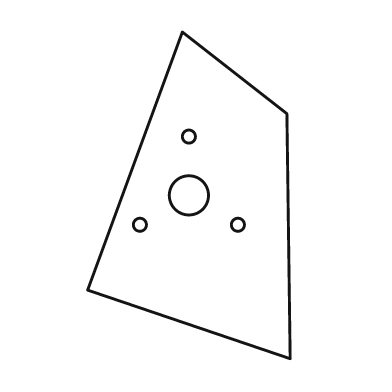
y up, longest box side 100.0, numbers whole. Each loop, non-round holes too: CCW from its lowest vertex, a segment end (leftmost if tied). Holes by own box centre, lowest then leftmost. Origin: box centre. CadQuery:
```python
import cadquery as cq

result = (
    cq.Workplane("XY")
    .moveTo(31.0, -50.0)
    .lineTo(30.0, 25.0)
    .lineTo(-2.0, 50.0)
    .lineTo(-31.0, -29.0)
    .close()
    .moveTo(-15.0, -9.0)
    .circle(2.0)
    .moveTo(15.0, -9.0)
    .circle(2.0)
    .moveTo(0.0, 0.0)
    .circle(6.0)
    .moveTo(0.0, 18.0)
    .circle(2.0)
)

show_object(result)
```